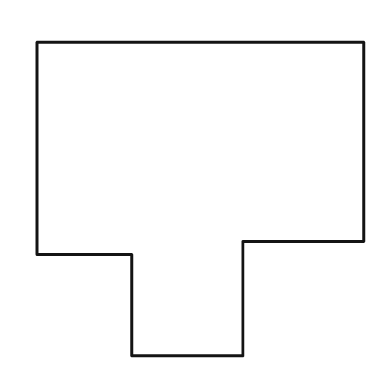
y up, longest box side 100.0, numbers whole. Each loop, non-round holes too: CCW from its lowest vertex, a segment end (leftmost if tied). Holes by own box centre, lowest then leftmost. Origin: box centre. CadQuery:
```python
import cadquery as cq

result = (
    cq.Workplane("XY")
    .moveTo(-21.0, -48.0)
    .lineTo(13.0, -48.0)
    .lineTo(13.0, -13.0)
    .lineTo(50.0, -13.0)
    .lineTo(50.0, 48.0)
    .lineTo(-50.0, 48.0)
    .lineTo(-50.0, -17.0)
    .lineTo(-21.0, -17.0)
    .close()
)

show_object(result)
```